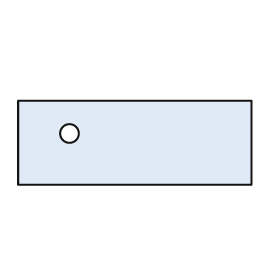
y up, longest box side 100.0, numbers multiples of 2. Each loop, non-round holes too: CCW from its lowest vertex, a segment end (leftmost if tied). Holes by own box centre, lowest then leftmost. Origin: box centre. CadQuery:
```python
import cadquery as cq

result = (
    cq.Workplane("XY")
    .moveTo(-50.0, -18.0)
    .lineTo(50.0, -18.0)
    .lineTo(50.0, 18.0)
    .lineTo(-50.0, 18.0)
    .close()
    .moveTo(-28.0, 4.0)
    .circle(4.0)
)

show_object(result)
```